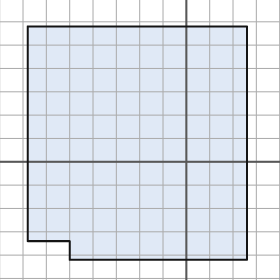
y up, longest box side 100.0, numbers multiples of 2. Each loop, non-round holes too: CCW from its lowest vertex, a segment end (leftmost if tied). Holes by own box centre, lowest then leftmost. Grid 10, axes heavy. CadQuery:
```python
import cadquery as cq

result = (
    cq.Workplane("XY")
    .moveTo(-50.0, -42.0)
    .lineTo(26.0, -42.0)
    .lineTo(26.0, 58.0)
    .lineTo(-68.0, 58.0)
    .lineTo(-68.0, -34.0)
    .lineTo(-50.0, -34.0)
    .close()
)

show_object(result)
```